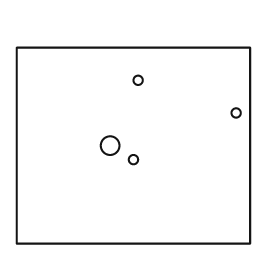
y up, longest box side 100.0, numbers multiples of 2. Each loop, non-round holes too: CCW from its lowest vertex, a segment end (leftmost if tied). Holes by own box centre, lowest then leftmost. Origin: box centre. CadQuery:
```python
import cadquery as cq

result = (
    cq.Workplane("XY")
    .moveTo(-50.0, -42.0)
    .lineTo(50.0, -42.0)
    .lineTo(50.0, 42.0)
    .lineTo(-50.0, 42.0)
    .close()
    .moveTo(0.0, -6.0)
    .circle(2.0)
    .moveTo(-10.0, 0.0)
    .circle(4.0)
    .moveTo(44.0, 14.0)
    .circle(2.0)
    .moveTo(2.0, 28.0)
    .circle(2.0)
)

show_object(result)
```